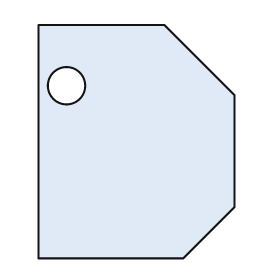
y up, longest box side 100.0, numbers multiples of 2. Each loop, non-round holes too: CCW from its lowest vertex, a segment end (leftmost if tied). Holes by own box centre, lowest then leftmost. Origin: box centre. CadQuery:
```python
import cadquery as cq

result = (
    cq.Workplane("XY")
    .moveTo(-42.0, -50.0)
    .lineTo(20.0, -50.0)
    .lineTo(42.0, -28.0)
    .lineTo(42.0, 20.0)
    .lineTo(12.0, 50.0)
    .lineTo(-42.0, 50.0)
    .close()
    .moveTo(-30.0, 24.0)
    .circle(8.0)
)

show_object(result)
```